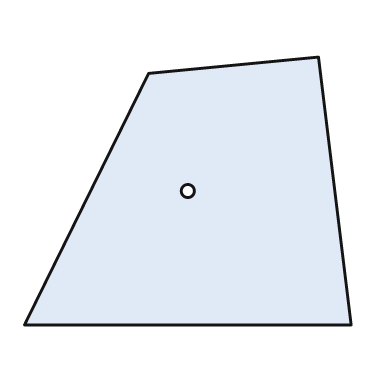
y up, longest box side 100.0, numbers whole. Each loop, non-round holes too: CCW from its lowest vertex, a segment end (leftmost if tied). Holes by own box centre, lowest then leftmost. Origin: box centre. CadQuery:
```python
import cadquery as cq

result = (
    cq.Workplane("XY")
    .moveTo(-50.0, -41.0)
    .lineTo(50.0, -41.0)
    .lineTo(40.0, 41.0)
    .lineTo(-12.0, 36.0)
    .close()
    .moveTo(0.0, 0.0)
    .circle(2.0)
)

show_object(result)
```